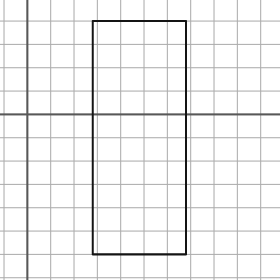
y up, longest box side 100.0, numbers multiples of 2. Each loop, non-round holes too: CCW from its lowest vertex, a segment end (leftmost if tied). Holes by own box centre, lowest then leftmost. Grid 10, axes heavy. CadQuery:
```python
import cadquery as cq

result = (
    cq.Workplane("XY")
    .moveTo(28.0, -60.0)
    .lineTo(68.0, -60.0)
    .lineTo(68.0, 40.0)
    .lineTo(28.0, 40.0)
    .close()
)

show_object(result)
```